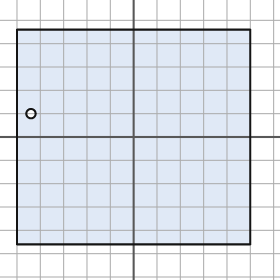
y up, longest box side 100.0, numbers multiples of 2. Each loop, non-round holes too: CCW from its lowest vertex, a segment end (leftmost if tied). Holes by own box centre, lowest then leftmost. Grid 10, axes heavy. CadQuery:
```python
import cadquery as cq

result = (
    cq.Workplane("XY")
    .moveTo(-50.0, -46.0)
    .lineTo(50.0, -46.0)
    .lineTo(50.0, 46.0)
    .lineTo(-50.0, 46.0)
    .close()
    .moveTo(-44.0, 10.0)
    .circle(2.0)
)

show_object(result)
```